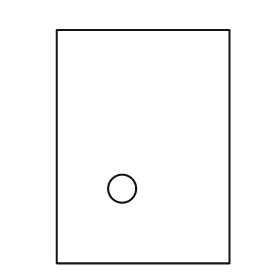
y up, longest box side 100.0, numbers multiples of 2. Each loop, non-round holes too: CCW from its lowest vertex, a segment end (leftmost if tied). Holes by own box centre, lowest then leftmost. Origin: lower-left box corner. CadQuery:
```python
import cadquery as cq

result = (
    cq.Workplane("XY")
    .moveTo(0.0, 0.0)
    .lineTo(74.0, 0.0)
    .lineTo(74.0, 100.0)
    .lineTo(0.0, 100.0)
    .close()
    .moveTo(28.0, 32.0)
    .circle(6.0)
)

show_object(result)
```